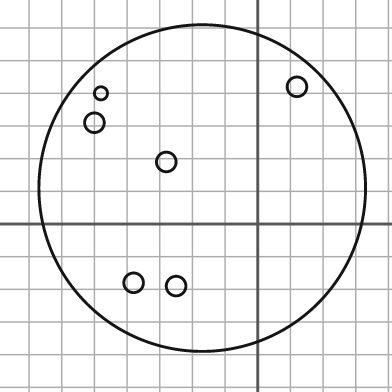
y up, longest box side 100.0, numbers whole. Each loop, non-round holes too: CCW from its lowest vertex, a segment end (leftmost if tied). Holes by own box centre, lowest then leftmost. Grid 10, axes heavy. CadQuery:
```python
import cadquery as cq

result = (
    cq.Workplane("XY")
    .moveTo(-17.0, 11.0)
    .circle(50.0)
    .moveTo(-25.0, -19.0)
    .circle(3.0)
    .moveTo(-38.0, -18.0)
    .circle(3.0)
    .moveTo(-28.0, 19.0)
    .circle(3.0)
    .moveTo(-50.0, 31.0)
    .circle(3.0)
    .moveTo(-48.0, 40.0)
    .circle(2.0)
    .moveTo(12.0, 42.0)
    .circle(3.0)
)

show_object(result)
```